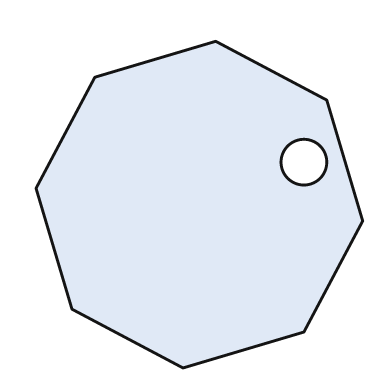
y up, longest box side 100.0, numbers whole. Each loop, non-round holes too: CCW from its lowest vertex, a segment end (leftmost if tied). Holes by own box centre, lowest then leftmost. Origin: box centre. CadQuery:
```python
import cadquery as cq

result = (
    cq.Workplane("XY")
    .moveTo(-5.0, -50.0)
    .lineTo(32.0, -39.0)
    .lineTo(50.0, -5.0)
    .lineTo(39.0, 32.0)
    .lineTo(5.0, 50.0)
    .lineTo(-32.0, 39.0)
    .lineTo(-50.0, 5.0)
    .lineTo(-39.0, -32.0)
    .close()
    .moveTo(32.0, 13.0)
    .circle(7.0)
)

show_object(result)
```